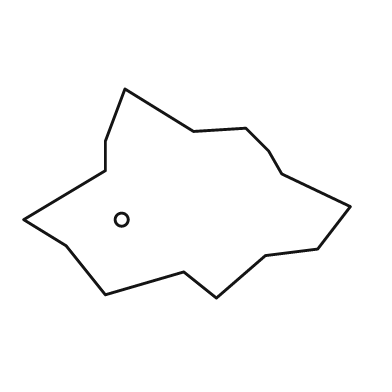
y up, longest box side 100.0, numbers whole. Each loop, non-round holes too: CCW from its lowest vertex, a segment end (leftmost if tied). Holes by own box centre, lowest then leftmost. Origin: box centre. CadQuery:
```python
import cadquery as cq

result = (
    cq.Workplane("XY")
    .moveTo(9.0, -32.0)
    .lineTo(24.0, -19.0)
    .lineTo(40.0, -17.0)
    .lineTo(50.0, -4.0)
    .lineTo(29.0, 6.0)
    .lineTo(25.0, 13.0)
    .lineTo(18.0, 20.0)
    .lineTo(2.0, 19.0)
    .lineTo(-19.0, 32.0)
    .lineTo(-25.0, 16.0)
    .lineTo(-25.0, 7.0)
    .lineTo(-50.0, -8.0)
    .lineTo(-37.0, -16.0)
    .lineTo(-25.0, -31.0)
    .lineTo(-1.0, -24.0)
    .close()
    .moveTo(-20.0, -8.0)
    .circle(2.0)
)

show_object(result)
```